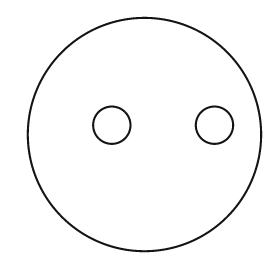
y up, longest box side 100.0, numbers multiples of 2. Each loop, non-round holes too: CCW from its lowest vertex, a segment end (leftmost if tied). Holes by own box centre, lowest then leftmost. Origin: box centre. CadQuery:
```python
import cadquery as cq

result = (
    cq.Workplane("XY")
    .moveTo(0.0, 0.0)
    .circle(50.0)
    .moveTo(-14.0, 4.0)
    .circle(8.0)
    .moveTo(30.0, 4.0)
    .circle(8.0)
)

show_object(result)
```